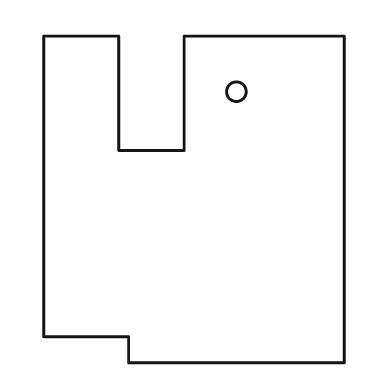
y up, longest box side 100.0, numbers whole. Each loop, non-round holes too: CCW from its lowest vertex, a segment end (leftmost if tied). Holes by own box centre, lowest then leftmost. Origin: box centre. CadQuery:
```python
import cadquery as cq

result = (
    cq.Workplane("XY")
    .moveTo(-20.0, -50.0)
    .lineTo(46.0, -50.0)
    .lineTo(46.0, 50.0)
    .lineTo(-3.0, 50.0)
    .lineTo(-3.0, 15.0)
    .lineTo(-23.0, 15.0)
    .lineTo(-23.0, 50.0)
    .lineTo(-46.0, 50.0)
    .lineTo(-46.0, -42.0)
    .lineTo(-20.0, -42.0)
    .close()
    .moveTo(13.0, 33.0)
    .circle(3.0)
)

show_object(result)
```